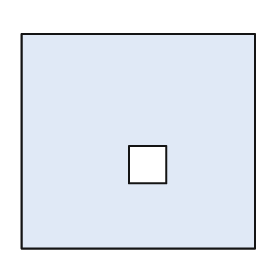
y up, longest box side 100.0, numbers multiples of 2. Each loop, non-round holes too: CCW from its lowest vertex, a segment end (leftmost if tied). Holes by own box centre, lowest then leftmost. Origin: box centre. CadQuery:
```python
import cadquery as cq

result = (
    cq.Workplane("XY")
    .moveTo(-50.0, -46.0)
    .lineTo(50.0, -46.0)
    .lineTo(50.0, 46.0)
    .lineTo(-50.0, 46.0)
    .close()
    .moveTo(-4.0, -18.0)
    .lineTo(12.0, -18.0)
    .lineTo(12.0, -2.0)
    .lineTo(-4.0, -2.0)
    .close()
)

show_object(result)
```